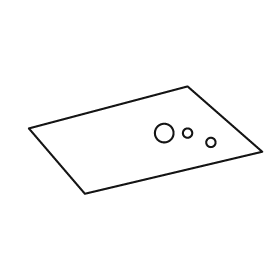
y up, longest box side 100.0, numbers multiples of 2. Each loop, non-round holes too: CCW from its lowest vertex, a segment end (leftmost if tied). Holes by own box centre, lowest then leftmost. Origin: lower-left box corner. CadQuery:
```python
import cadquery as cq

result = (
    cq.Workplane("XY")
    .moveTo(24.0, 0.0)
    .lineTo(100.0, 18.0)
    .lineTo(68.0, 46.0)
    .lineTo(0.0, 28.0)
    .close()
    .moveTo(78.0, 22.0)
    .circle(2.0)
    .moveTo(58.0, 26.0)
    .circle(4.0)
    .moveTo(68.0, 26.0)
    .circle(2.0)
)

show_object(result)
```